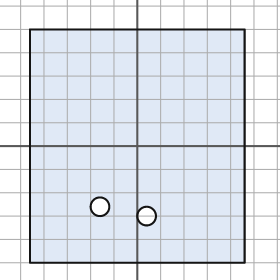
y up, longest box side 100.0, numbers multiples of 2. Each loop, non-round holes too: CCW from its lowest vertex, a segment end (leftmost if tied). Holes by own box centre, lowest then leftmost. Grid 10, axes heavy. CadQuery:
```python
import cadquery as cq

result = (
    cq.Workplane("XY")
    .moveTo(-46.0, -50.0)
    .lineTo(46.0, -50.0)
    .lineTo(46.0, 50.0)
    .lineTo(-46.0, 50.0)
    .close()
    .moveTo(4.0, -30.0)
    .circle(4.0)
    .moveTo(-16.0, -26.0)
    .circle(4.0)
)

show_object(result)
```